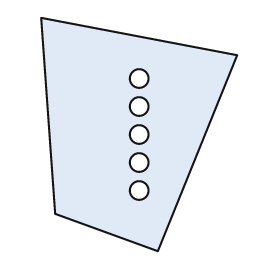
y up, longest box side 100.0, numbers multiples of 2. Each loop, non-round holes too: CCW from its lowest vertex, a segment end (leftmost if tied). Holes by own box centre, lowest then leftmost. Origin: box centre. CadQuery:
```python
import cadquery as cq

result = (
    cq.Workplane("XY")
    .moveTo(8.0, -50.0)
    .lineTo(42.0, 34.0)
    .lineTo(-42.0, 50.0)
    .lineTo(-36.0, -34.0)
    .close()
    .moveTo(0.0, -24.0)
    .circle(4.0)
    .moveTo(0.0, -12.0)
    .circle(4.0)
    .moveTo(0.0, 0.0)
    .circle(4.0)
    .moveTo(0.0, 12.0)
    .circle(4.0)
    .moveTo(0.0, 24.0)
    .circle(4.0)
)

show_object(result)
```